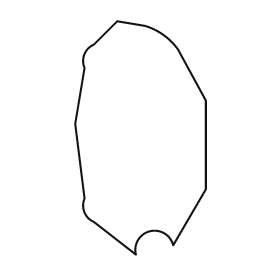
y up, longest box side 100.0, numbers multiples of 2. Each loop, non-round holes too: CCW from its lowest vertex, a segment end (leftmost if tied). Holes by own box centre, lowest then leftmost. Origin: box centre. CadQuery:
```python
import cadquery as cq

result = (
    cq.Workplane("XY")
    .moveTo(-2.0, -50.0)
    .threePointArc((4.0, -40.0), (14.0, -46.0))
    .lineTo(28.0, -22.0)
    .lineTo(28.0, 16.0)
    .lineTo(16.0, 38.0)
    .threePointArc((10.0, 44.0), (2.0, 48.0))
    .lineTo(-10.0, 50.0)
    .lineTo(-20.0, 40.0)
    .threePointArc((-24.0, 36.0), (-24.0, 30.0))
    .lineTo(-28.0, 6.0)
    .lineTo(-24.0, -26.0)
    .threePointArc((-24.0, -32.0), (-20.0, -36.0))
    .close()
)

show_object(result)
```